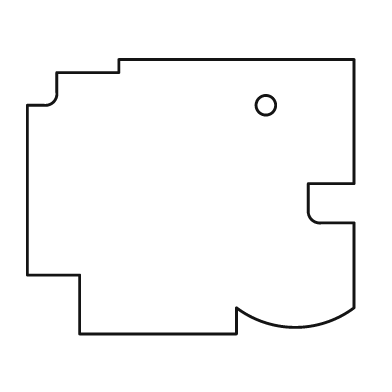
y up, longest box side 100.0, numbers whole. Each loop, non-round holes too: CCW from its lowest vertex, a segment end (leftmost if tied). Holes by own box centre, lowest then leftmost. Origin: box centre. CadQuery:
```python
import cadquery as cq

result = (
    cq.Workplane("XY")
    .moveTo(-34.0, -42.0)
    .lineTo(14.0, -42.0)
    .lineTo(14.0, -34.0)
    .threePointArc((32.0, -40.0), (50.0, -34.0))
    .lineTo(50.0, -8.0)
    .lineTo(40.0, -8.0)
    .threePointArc((37.0, -7.0), (36.0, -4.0))
    .lineTo(36.0, 4.0)
    .lineTo(50.0, 4.0)
    .lineTo(50.0, 42.0)
    .lineTo(-22.0, 42.0)
    .lineTo(-22.0, 38.0)
    .lineTo(-41.0, 38.0)
    .lineTo(-41.0, 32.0)
    .threePointArc((-42.0, 29.0), (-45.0, 28.0))
    .lineTo(-50.0, 28.0)
    .lineTo(-50.0, -24.0)
    .lineTo(-34.0, -24.0)
    .close()
    .moveTo(23.0, 28.0)
    .circle(3.0)
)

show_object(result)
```